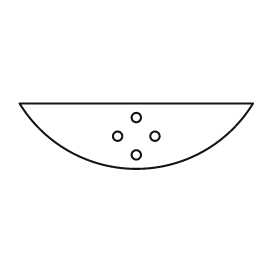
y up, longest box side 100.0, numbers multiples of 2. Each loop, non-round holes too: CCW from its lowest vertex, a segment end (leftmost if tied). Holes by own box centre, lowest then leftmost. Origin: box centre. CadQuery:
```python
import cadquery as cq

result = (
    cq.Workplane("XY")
    .moveTo(-50.0, 14.0)
    .threePointArc((0.0, -14.0), (50.0, 14.0))
    .close()
    .moveTo(0.0, -8.0)
    .circle(2.0)
    .moveTo(-8.0, 0.0)
    .circle(2.0)
    .moveTo(8.0, 0.0)
    .circle(2.0)
    .moveTo(0.0, 8.0)
    .circle(2.0)
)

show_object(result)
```